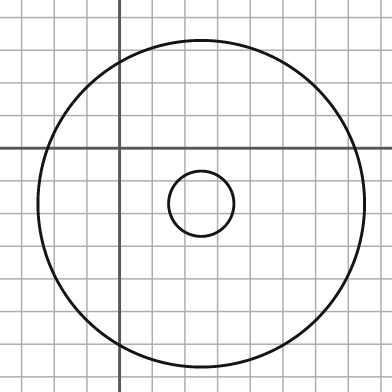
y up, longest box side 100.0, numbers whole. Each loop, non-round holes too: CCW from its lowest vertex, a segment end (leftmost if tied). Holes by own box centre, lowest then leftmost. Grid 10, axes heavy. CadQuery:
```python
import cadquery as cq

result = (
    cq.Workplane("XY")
    .moveTo(25.0, -17.0)
    .circle(50.0)
    .moveTo(25.0, -17.0)
    .circle(10.0)
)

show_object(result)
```